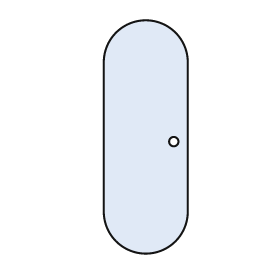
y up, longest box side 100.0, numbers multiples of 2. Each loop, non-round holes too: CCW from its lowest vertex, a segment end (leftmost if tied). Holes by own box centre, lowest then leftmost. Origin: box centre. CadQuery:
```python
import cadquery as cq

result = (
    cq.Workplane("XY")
    .moveTo(-18.0, -32.0)
    .threePointArc((0.0, -50.0), (18.0, -32.0))
    .lineTo(18.0, 32.0)
    .threePointArc((0.0, 50.0), (-18.0, 32.0))
    .close()
    .moveTo(12.0, -2.0)
    .circle(2.0)
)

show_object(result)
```